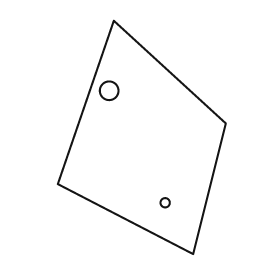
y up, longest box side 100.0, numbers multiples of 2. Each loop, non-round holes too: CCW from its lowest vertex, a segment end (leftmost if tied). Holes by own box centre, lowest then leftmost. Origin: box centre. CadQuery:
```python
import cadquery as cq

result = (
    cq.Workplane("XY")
    .moveTo(22.0, -50.0)
    .lineTo(36.0, 6.0)
    .lineTo(-12.0, 50.0)
    .lineTo(-36.0, -20.0)
    .close()
    .moveTo(10.0, -28.0)
    .circle(2.0)
    .moveTo(-14.0, 20.0)
    .circle(4.0)
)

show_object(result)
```